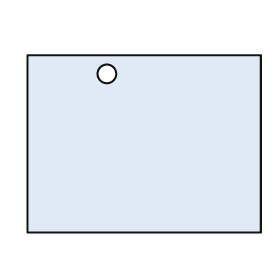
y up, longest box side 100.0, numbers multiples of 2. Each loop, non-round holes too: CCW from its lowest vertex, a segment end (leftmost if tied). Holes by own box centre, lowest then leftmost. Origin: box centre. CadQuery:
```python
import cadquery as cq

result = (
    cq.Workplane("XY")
    .moveTo(-50.0, -38.0)
    .lineTo(50.0, -38.0)
    .lineTo(50.0, 38.0)
    .lineTo(-50.0, 38.0)
    .close()
    .moveTo(-16.0, 30.0)
    .circle(4.0)
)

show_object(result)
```